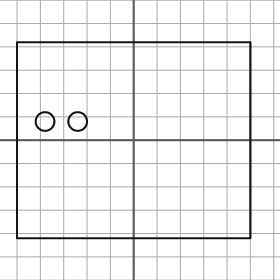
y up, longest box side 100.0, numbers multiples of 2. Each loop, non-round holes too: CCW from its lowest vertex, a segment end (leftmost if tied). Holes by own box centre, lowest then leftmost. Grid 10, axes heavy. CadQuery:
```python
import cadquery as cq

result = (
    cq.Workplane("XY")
    .moveTo(-50.0, -42.0)
    .lineTo(50.0, -42.0)
    .lineTo(50.0, 42.0)
    .lineTo(-50.0, 42.0)
    .close()
    .moveTo(-38.0, 8.0)
    .circle(4.0)
    .moveTo(-24.0, 8.0)
    .circle(4.0)
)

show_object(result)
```